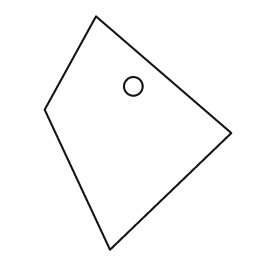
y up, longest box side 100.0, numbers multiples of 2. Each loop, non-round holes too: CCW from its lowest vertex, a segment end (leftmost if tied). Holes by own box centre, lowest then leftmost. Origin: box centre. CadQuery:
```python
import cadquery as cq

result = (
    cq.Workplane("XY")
    .moveTo(-12.0, -50.0)
    .lineTo(40.0, 0.0)
    .lineTo(-18.0, 50.0)
    .lineTo(-40.0, 10.0)
    .close()
    .moveTo(-2.0, 20.0)
    .circle(4.0)
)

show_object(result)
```